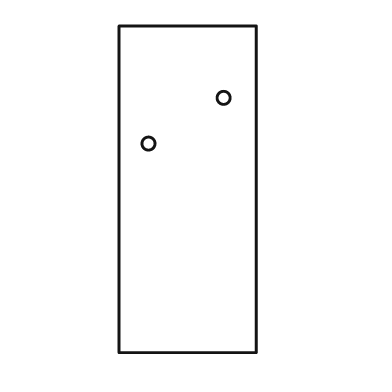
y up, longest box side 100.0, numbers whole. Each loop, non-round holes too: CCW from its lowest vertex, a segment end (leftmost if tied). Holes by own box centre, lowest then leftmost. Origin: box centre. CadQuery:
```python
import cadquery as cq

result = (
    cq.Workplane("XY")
    .moveTo(-21.0, -50.0)
    .lineTo(21.0, -50.0)
    .lineTo(21.0, 50.0)
    .lineTo(-21.0, 50.0)
    .close()
    .moveTo(-12.0, 14.0)
    .circle(2.0)
    .moveTo(11.0, 28.0)
    .circle(2.0)
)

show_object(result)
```